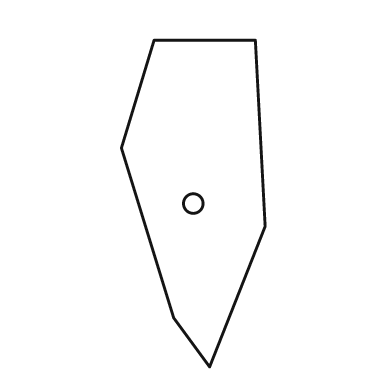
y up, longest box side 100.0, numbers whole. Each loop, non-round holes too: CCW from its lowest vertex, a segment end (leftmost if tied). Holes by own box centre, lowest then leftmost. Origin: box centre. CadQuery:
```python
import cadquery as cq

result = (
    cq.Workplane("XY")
    .moveTo(5.0, -50.0)
    .lineTo(22.0, -7.0)
    .lineTo(19.0, 50.0)
    .lineTo(-12.0, 50.0)
    .lineTo(-22.0, 17.0)
    .lineTo(-6.0, -35.0)
    .close()
    .moveTo(0.0, 0.0)
    .circle(3.0)
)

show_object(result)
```